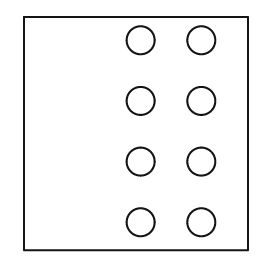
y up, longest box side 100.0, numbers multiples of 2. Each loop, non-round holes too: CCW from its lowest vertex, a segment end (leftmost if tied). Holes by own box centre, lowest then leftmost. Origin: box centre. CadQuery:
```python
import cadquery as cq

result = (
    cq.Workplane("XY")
    .moveTo(-48.0, -50.0)
    .lineTo(48.0, -50.0)
    .lineTo(48.0, 50.0)
    .lineTo(-48.0, 50.0)
    .close()
    .moveTo(2.0, -38.0)
    .circle(6.0)
    .moveTo(28.0, -38.0)
    .circle(6.0)
    .moveTo(2.0, -12.0)
    .circle(6.0)
    .moveTo(28.0, -12.0)
    .circle(6.0)
    .moveTo(2.0, 14.0)
    .circle(6.0)
    .moveTo(28.0, 14.0)
    .circle(6.0)
    .moveTo(2.0, 40.0)
    .circle(6.0)
    .moveTo(28.0, 40.0)
    .circle(6.0)
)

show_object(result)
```